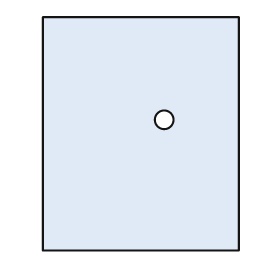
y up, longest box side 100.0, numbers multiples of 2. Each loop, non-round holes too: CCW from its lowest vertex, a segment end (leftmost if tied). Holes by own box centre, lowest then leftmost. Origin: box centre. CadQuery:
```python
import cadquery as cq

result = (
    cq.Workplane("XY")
    .moveTo(-42.0, -50.0)
    .lineTo(42.0, -50.0)
    .lineTo(42.0, 50.0)
    .lineTo(-42.0, 50.0)
    .close()
    .moveTo(10.0, 6.0)
    .circle(4.0)
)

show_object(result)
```